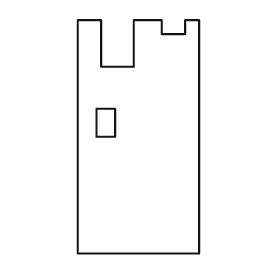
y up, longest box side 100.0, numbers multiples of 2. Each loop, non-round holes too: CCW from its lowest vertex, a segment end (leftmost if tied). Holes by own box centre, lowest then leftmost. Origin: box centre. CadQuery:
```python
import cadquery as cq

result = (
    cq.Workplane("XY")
    .moveTo(-26.0, -50.0)
    .lineTo(26.0, -50.0)
    .lineTo(26.0, 50.0)
    .lineTo(20.0, 50.0)
    .lineTo(20.0, 44.0)
    .lineTo(10.0, 44.0)
    .lineTo(10.0, 50.0)
    .lineTo(-2.0, 50.0)
    .lineTo(-2.0, 30.0)
    .lineTo(-16.0, 30.0)
    .lineTo(-16.0, 50.0)
    .lineTo(-26.0, 50.0)
    .close()
    .moveTo(-18.0, 0.0)
    .lineTo(-10.0, 0.0)
    .lineTo(-10.0, 12.0)
    .lineTo(-18.0, 12.0)
    .close()
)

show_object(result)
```